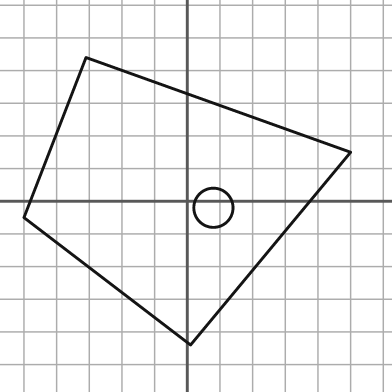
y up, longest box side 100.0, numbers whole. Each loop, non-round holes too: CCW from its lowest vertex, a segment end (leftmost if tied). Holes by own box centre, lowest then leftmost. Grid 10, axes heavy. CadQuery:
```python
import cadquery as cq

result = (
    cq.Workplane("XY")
    .moveTo(1.0, -44.0)
    .lineTo(50.0, 15.0)
    .lineTo(-31.0, 44.0)
    .lineTo(-50.0, -5.0)
    .close()
    .moveTo(8.0, -2.0)
    .circle(6.0)
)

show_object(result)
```